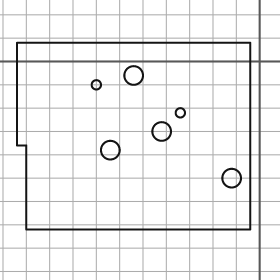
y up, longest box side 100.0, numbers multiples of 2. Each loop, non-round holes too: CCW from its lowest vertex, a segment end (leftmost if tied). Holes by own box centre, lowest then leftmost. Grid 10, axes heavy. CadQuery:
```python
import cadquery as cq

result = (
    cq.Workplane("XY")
    .moveTo(-100.0, -72.0)
    .lineTo(-4.0, -72.0)
    .lineTo(-4.0, 8.0)
    .lineTo(-104.0, 8.0)
    .lineTo(-104.0, -36.0)
    .lineTo(-100.0, -36.0)
    .close()
    .moveTo(-12.0, -50.0)
    .circle(4.0)
    .moveTo(-64.0, -38.0)
    .circle(4.0)
    .moveTo(-42.0, -30.0)
    .circle(4.0)
    .moveTo(-34.0, -22.0)
    .circle(2.0)
    .moveTo(-70.0, -10.0)
    .circle(2.0)
    .moveTo(-54.0, -6.0)
    .circle(4.0)
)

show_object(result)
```